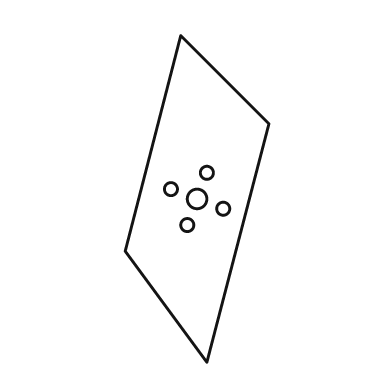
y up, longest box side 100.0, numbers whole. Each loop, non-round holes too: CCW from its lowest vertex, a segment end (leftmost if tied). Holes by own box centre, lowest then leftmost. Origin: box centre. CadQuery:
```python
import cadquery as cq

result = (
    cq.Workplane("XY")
    .moveTo(3.0, -50.0)
    .lineTo(22.0, 23.0)
    .lineTo(-5.0, 50.0)
    .lineTo(-22.0, -16.0)
    .close()
    .moveTo(-3.0, -8.0)
    .circle(2.0)
    .moveTo(8.0, -3.0)
    .circle(2.0)
    .moveTo(0.0, 0.0)
    .circle(3.0)
    .moveTo(-8.0, 3.0)
    .circle(2.0)
    .moveTo(3.0, 8.0)
    .circle(2.0)
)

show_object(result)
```